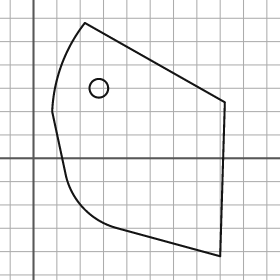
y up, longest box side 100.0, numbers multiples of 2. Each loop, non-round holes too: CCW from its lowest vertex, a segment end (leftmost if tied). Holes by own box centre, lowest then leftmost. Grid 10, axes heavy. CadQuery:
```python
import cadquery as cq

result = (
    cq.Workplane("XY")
    .moveTo(80.0, -42.0)
    .lineTo(82.0, 24.0)
    .lineTo(22.0, 58.0)
    .threePointArc((12.0, 40.0), (8.0, 20.0))
    .lineTo(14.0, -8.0)
    .threePointArc((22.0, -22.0), (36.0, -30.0))
    .close()
    .moveTo(28.0, 30.0)
    .circle(4.0)
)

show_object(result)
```